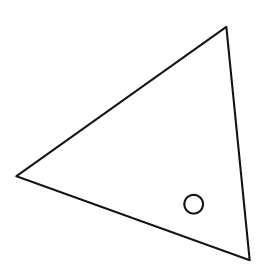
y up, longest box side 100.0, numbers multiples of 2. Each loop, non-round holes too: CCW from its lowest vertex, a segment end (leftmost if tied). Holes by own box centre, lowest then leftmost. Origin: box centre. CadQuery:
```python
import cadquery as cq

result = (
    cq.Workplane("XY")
    .moveTo(50.0, -50.0)
    .lineTo(40.0, 50.0)
    .lineTo(-50.0, -14.0)
    .close()
    .moveTo(26.0, -26.0)
    .circle(4.0)
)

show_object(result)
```